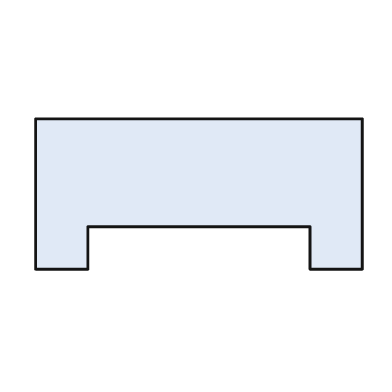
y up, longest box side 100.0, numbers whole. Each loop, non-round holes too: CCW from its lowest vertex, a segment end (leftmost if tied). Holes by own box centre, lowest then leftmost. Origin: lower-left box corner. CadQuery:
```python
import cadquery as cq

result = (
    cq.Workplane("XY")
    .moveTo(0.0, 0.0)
    .lineTo(16.0, 0.0)
    .lineTo(16.0, 13.0)
    .lineTo(84.0, 13.0)
    .lineTo(84.0, 0.0)
    .lineTo(100.0, 0.0)
    .lineTo(100.0, 46.0)
    .lineTo(0.0, 46.0)
    .close()
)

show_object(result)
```